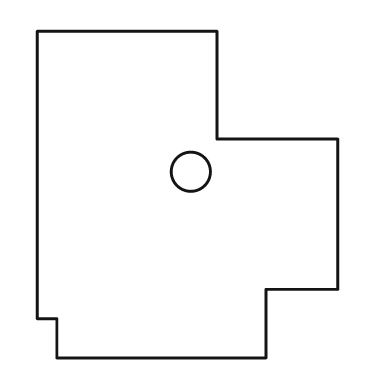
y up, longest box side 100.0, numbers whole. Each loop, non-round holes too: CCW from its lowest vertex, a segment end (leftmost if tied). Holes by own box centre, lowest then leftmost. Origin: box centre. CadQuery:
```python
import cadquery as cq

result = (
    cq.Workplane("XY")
    .moveTo(-40.0, -50.0)
    .lineTo(24.0, -50.0)
    .lineTo(24.0, -29.0)
    .lineTo(46.0, -29.0)
    .lineTo(46.0, 17.0)
    .lineTo(9.0, 17.0)
    .lineTo(9.0, 50.0)
    .lineTo(-46.0, 50.0)
    .lineTo(-46.0, -38.0)
    .lineTo(-40.0, -38.0)
    .close()
    .moveTo(1.0, 7.0)
    .circle(6.0)
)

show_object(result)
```